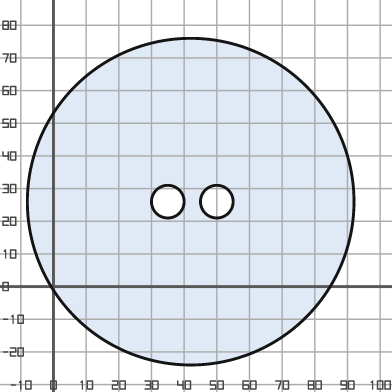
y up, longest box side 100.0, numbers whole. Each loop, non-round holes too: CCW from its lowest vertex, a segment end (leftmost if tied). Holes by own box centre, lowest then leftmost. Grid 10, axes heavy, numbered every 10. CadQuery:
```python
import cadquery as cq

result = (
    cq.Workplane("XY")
    .moveTo(42.0, 26.0)
    .circle(50.0)
    .moveTo(35.0, 26.0)
    .circle(5.0)
    .moveTo(50.0, 26.0)
    .circle(5.0)
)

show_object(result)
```